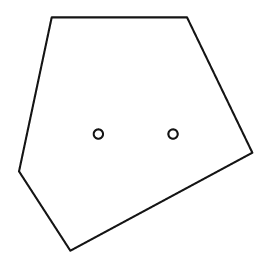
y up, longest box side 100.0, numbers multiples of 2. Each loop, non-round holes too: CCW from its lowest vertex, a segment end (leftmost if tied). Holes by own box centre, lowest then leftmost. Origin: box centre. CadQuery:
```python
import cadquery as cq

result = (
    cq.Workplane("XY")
    .moveTo(-28.0, -50.0)
    .lineTo(50.0, -8.0)
    .lineTo(22.0, 50.0)
    .lineTo(-36.0, 50.0)
    .lineTo(-50.0, -16.0)
    .close()
    .moveTo(-16.0, 0.0)
    .circle(2.0)
    .moveTo(16.0, 0.0)
    .circle(2.0)
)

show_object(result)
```